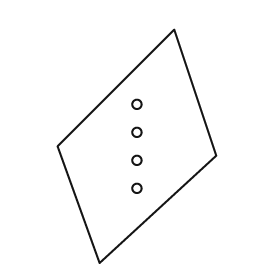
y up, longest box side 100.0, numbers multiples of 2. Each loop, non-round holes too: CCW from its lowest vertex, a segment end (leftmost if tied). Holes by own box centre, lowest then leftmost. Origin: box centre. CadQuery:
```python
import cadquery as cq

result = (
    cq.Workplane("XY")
    .moveTo(-16.0, -50.0)
    .lineTo(34.0, -4.0)
    .lineTo(16.0, 50.0)
    .lineTo(-34.0, 0.0)
    .close()
    .moveTo(0.0, -18.0)
    .circle(2.0)
    .moveTo(0.0, -6.0)
    .circle(2.0)
    .moveTo(0.0, 6.0)
    .circle(2.0)
    .moveTo(0.0, 18.0)
    .circle(2.0)
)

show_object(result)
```